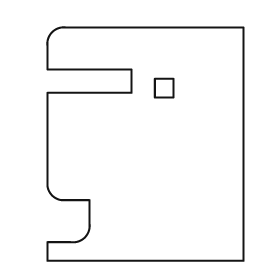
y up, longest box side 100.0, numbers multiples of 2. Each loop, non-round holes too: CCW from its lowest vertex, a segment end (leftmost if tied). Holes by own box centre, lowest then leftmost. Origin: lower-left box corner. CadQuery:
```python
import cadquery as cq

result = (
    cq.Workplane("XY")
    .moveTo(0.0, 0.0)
    .lineTo(84.0, 0.0)
    .lineTo(84.0, 100.0)
    .lineTo(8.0, 100.0)
    .threePointArc((2.0, 98.0), (0.0, 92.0))
    .lineTo(0.0, 82.0)
    .lineTo(36.0, 82.0)
    .lineTo(36.0, 72.0)
    .lineTo(0.0, 72.0)
    .lineTo(0.0, 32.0)
    .threePointArc((2.0, 28.0), (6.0, 26.0))
    .lineTo(18.0, 26.0)
    .lineTo(18.0, 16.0)
    .threePointArc((16.0, 10.0), (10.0, 8.0))
    .lineTo(0.0, 8.0)
    .close()
    .moveTo(46.0, 70.0)
    .lineTo(54.0, 70.0)
    .lineTo(54.0, 78.0)
    .lineTo(46.0, 78.0)
    .close()
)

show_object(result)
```